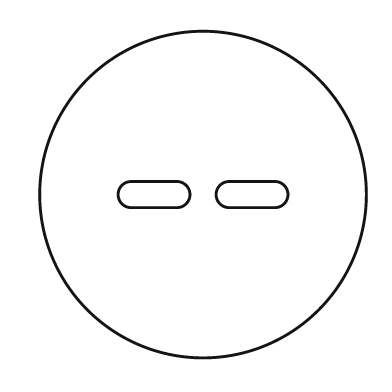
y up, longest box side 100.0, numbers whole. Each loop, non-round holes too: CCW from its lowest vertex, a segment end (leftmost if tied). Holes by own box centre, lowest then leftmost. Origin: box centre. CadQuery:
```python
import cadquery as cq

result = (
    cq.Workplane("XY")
    .moveTo(0.0, 0.0)
    .circle(50.0)
    .moveTo(-22.0, -4.0)
    .lineTo(-8.0, -4.0)
    .threePointArc((-4.0, 0.0), (-8.0, 4.0))
    .lineTo(-22.0, 4.0)
    .threePointArc((-26.0, 0.0), (-22.0, -4.0))
    .close()
    .moveTo(8.0, -4.0)
    .lineTo(22.0, -4.0)
    .threePointArc((26.0, 0.0), (22.0, 4.0))
    .lineTo(8.0, 4.0)
    .threePointArc((4.0, 0.0), (8.0, -4.0))
    .close()
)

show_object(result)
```